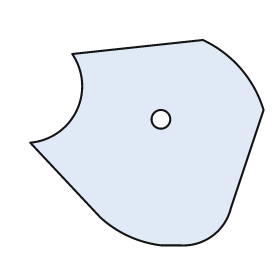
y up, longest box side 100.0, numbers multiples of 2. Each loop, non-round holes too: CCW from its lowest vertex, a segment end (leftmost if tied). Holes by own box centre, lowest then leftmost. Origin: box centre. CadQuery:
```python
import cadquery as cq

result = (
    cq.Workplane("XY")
    .moveTo(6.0, -44.0)
    .lineTo(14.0, -44.0)
    .threePointArc((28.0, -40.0), (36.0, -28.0))
    .lineTo(50.0, 14.0)
    .threePointArc((40.0, 32.0), (24.0, 44.0))
    .lineTo(-32.0, 38.0)
    .threePointArc((-30.0, 14.0), (-50.0, 0.0))
    .lineTo(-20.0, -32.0)
    .threePointArc((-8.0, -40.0), (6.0, -44.0))
    .close()
    .moveTo(6.0, 10.0)
    .circle(4.0)
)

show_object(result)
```